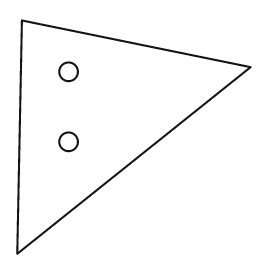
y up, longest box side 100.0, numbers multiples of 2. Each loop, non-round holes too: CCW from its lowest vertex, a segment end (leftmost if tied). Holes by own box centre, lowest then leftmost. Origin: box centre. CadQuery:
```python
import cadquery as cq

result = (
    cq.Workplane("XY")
    .moveTo(-50.0, -50.0)
    .lineTo(50.0, 30.0)
    .lineTo(-48.0, 50.0)
    .close()
    .moveTo(-28.0, -2.0)
    .circle(4.0)
    .moveTo(-28.0, 28.0)
    .circle(4.0)
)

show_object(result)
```